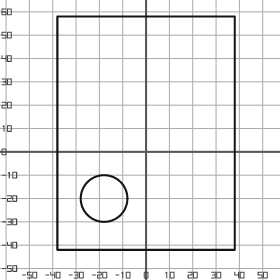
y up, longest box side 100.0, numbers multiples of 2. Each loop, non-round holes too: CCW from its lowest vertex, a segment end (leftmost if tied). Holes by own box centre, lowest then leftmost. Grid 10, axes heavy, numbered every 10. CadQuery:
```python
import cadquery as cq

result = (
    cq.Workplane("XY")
    .moveTo(-38.0, -42.0)
    .lineTo(38.0, -42.0)
    .lineTo(38.0, 58.0)
    .lineTo(-38.0, 58.0)
    .close()
    .moveTo(-18.0, -20.0)
    .circle(10.0)
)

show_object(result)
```